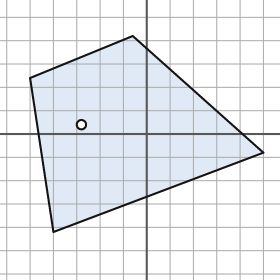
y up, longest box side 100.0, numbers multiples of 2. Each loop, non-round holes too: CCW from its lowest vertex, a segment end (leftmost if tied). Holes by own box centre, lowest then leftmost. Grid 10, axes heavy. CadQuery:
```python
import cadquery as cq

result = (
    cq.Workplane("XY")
    .moveTo(-40.0, -42.0)
    .lineTo(50.0, -8.0)
    .lineTo(-6.0, 42.0)
    .lineTo(-50.0, 24.0)
    .close()
    .moveTo(-28.0, 4.0)
    .circle(2.0)
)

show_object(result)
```